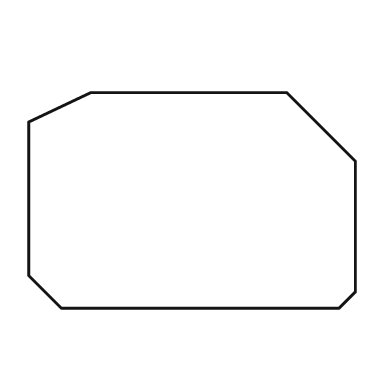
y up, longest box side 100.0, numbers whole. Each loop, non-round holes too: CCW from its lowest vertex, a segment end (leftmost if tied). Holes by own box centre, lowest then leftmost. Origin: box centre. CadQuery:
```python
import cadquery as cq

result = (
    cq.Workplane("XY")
    .moveTo(-40.0, -33.0)
    .lineTo(45.0, -33.0)
    .lineTo(50.0, -28.0)
    .lineTo(50.0, 12.0)
    .lineTo(29.0, 33.0)
    .lineTo(-31.0, 33.0)
    .lineTo(-50.0, 24.0)
    .lineTo(-50.0, -23.0)
    .close()
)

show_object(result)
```